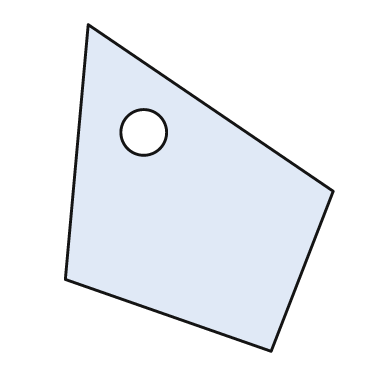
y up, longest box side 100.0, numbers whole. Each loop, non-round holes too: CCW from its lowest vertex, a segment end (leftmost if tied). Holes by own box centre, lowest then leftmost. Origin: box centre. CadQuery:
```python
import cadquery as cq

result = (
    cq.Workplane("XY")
    .moveTo(22.0, -50.0)
    .lineTo(41.0, -1.0)
    .lineTo(-34.0, 50.0)
    .lineTo(-41.0, -28.0)
    .close()
    .moveTo(-17.0, 17.0)
    .circle(7.0)
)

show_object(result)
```